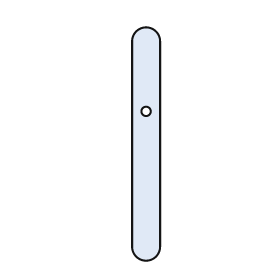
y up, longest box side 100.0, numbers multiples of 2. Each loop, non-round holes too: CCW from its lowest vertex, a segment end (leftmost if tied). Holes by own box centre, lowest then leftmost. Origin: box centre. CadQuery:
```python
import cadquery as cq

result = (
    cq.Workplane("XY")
    .moveTo(-6.0, -44.0)
    .threePointArc((0.0, -50.0), (6.0, -44.0))
    .lineTo(6.0, 44.0)
    .threePointArc((0.0, 50.0), (-6.0, 44.0))
    .close()
    .moveTo(0.0, 14.0)
    .circle(2.0)
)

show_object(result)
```